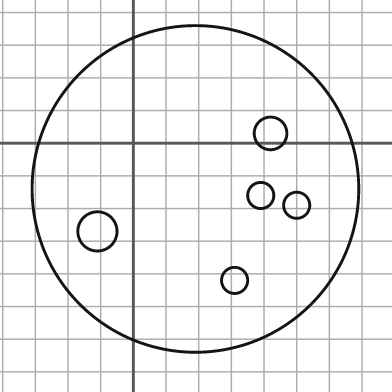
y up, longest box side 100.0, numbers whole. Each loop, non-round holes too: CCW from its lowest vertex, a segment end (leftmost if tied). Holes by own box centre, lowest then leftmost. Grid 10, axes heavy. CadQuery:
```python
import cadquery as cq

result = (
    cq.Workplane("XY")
    .moveTo(19.0, -14.0)
    .circle(50.0)
    .moveTo(31.0, -42.0)
    .circle(4.0)
    .moveTo(-11.0, -27.0)
    .circle(6.0)
    .moveTo(50.0, -19.0)
    .circle(4.0)
    .moveTo(39.0, -16.0)
    .circle(4.0)
    .moveTo(42.0, 3.0)
    .circle(5.0)
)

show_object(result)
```